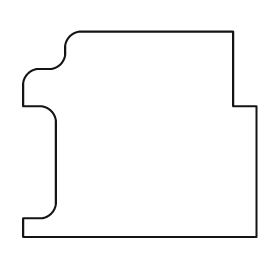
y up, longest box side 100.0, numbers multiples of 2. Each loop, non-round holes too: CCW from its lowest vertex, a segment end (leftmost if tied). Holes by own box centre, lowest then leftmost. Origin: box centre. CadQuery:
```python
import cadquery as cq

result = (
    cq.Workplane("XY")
    .moveTo(-50.0, -44.0)
    .lineTo(50.0, -44.0)
    .lineTo(50.0, 12.0)
    .lineTo(40.0, 12.0)
    .lineTo(40.0, 44.0)
    .lineTo(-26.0, 44.0)
    .threePointArc((-30.0, 42.0), (-32.0, 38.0))
    .lineTo(-32.0, 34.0)
    .threePointArc((-34.0, 30.0), (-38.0, 28.0))
    .lineTo(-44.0, 28.0)
    .threePointArc((-48.0, 26.0), (-50.0, 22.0))
    .lineTo(-50.0, 12.0)
    .lineTo(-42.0, 12.0)
    .threePointArc((-38.0, 10.0), (-36.0, 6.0))
    .lineTo(-36.0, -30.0)
    .threePointArc((-38.0, -34.0), (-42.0, -36.0))
    .lineTo(-50.0, -36.0)
    .close()
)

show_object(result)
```